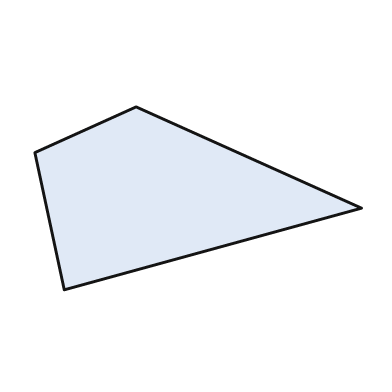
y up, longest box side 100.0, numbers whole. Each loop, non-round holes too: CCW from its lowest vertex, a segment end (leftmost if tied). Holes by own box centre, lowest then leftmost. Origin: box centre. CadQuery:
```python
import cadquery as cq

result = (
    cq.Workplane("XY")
    .moveTo(-41.0, -28.0)
    .lineTo(50.0, -3.0)
    .lineTo(-19.0, 28.0)
    .lineTo(-50.0, 14.0)
    .close()
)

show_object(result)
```